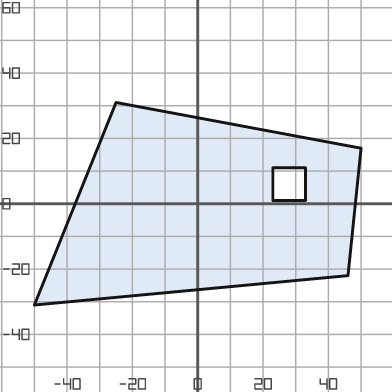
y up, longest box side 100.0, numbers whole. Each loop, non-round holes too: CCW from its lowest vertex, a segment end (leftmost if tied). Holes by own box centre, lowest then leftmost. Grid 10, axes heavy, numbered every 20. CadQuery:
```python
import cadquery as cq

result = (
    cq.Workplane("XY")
    .moveTo(-50.0, -31.0)
    .lineTo(46.0, -22.0)
    .lineTo(50.0, 17.0)
    .lineTo(-25.0, 31.0)
    .close()
    .moveTo(23.0, 1.0)
    .lineTo(33.0, 1.0)
    .lineTo(33.0, 11.0)
    .lineTo(23.0, 11.0)
    .close()
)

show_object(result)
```